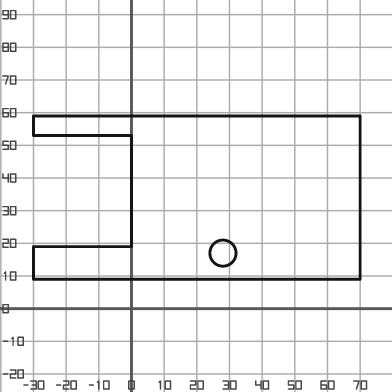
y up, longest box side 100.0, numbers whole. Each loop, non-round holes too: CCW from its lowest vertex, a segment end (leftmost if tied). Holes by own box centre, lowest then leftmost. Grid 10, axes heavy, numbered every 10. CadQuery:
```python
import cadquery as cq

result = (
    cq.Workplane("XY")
    .moveTo(-30.0, 9.0)
    .lineTo(70.0, 9.0)
    .lineTo(70.0, 59.0)
    .lineTo(-30.0, 59.0)
    .lineTo(-30.0, 53.0)
    .lineTo(0.0, 53.0)
    .lineTo(0.0, 19.0)
    .lineTo(-30.0, 19.0)
    .close()
    .moveTo(28.0, 17.0)
    .circle(4.0)
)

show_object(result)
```